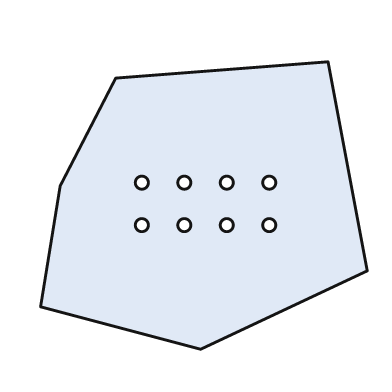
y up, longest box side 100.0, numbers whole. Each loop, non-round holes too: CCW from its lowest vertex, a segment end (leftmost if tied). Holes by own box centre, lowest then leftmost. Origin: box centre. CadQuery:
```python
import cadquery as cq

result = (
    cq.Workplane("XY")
    .moveTo(-1.0, -44.0)
    .lineTo(50.0, -20.0)
    .lineTo(38.0, 44.0)
    .lineTo(-27.0, 39.0)
    .lineTo(-44.0, 6.0)
    .lineTo(-50.0, -31.0)
    .close()
    .moveTo(-19.0, -6.0)
    .circle(2.0)
    .moveTo(-6.0, -6.0)
    .circle(2.0)
    .moveTo(7.0, -6.0)
    .circle(2.0)
    .moveTo(20.0, -6.0)
    .circle(2.0)
    .moveTo(-19.0, 7.0)
    .circle(2.0)
    .moveTo(-6.0, 7.0)
    .circle(2.0)
    .moveTo(7.0, 7.0)
    .circle(2.0)
    .moveTo(20.0, 7.0)
    .circle(2.0)
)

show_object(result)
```